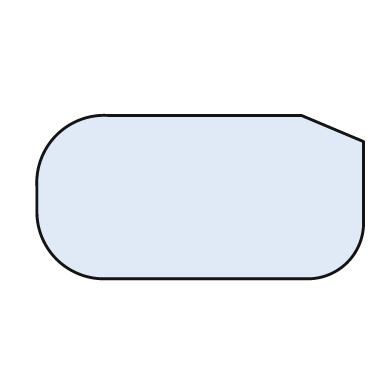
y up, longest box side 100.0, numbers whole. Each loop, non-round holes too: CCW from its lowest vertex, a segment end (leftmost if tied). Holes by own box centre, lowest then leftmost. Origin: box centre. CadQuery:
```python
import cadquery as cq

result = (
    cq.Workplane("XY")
    .moveTo(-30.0, -25.0)
    .lineTo(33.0, -25.0)
    .threePointArc((45.0, -20.0), (50.0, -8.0))
    .lineTo(50.0, 17.0)
    .lineTo(31.0, 25.0)
    .lineTo(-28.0, 25.0)
    .threePointArc((-44.0, 19.0), (-50.0, 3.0))
    .lineTo(-50.0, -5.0)
    .threePointArc((-44.0, -19.0), (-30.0, -25.0))
    .close()
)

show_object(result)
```